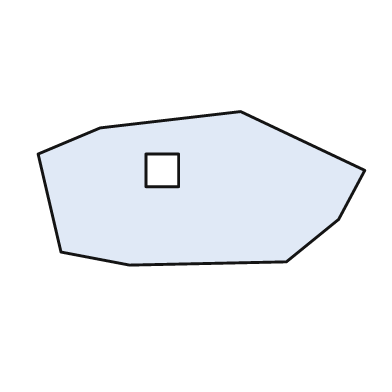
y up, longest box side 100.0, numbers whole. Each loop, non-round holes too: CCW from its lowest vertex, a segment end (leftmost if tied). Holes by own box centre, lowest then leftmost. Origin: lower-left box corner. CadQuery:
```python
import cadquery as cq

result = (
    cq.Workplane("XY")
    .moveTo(28.0, 0.0)
    .lineTo(76.0, 1.0)
    .lineTo(92.0, 14.0)
    .lineTo(100.0, 29.0)
    .lineTo(62.0, 47.0)
    .lineTo(19.0, 42.0)
    .lineTo(0.0, 34.0)
    .lineTo(7.0, 4.0)
    .close()
    .moveTo(33.0, 24.0)
    .lineTo(43.0, 24.0)
    .lineTo(43.0, 34.0)
    .lineTo(33.0, 34.0)
    .close()
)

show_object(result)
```